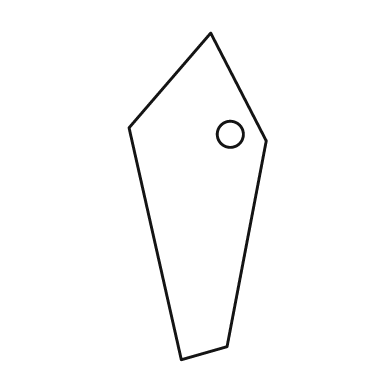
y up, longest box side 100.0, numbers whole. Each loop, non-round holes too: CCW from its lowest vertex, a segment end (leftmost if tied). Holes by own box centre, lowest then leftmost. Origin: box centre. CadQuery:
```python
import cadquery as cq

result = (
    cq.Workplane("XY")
    .moveTo(-5.0, -50.0)
    .lineTo(9.0, -46.0)
    .lineTo(21.0, 17.0)
    .lineTo(4.0, 50.0)
    .lineTo(-21.0, 21.0)
    .close()
    .moveTo(10.0, 19.0)
    .circle(4.0)
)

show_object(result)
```